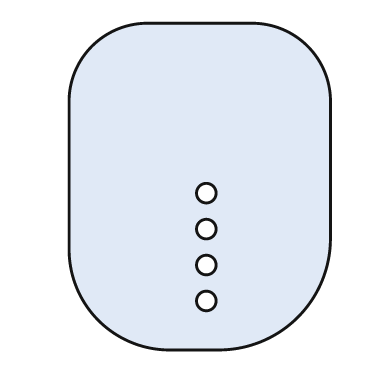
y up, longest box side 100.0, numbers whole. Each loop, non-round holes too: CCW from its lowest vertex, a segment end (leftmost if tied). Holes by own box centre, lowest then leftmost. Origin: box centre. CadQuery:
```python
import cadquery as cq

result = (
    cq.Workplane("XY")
    .moveTo(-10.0, -50.0)
    .lineTo(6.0, -50.0)
    .threePointArc((30.0, -40.0), (40.0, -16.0))
    .lineTo(40.0, 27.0)
    .threePointArc((33.0, 43.0), (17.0, 50.0))
    .lineTo(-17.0, 50.0)
    .threePointArc((-33.0, 43.0), (-40.0, 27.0))
    .lineTo(-40.0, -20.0)
    .threePointArc((-31.0, -41.0), (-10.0, -50.0))
    .close()
    .moveTo(2.0, -35.0)
    .circle(3.0)
    .moveTo(2.0, -24.0)
    .circle(3.0)
    .moveTo(2.0, -13.0)
    .circle(3.0)
    .moveTo(2.0, -2.0)
    .circle(3.0)
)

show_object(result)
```